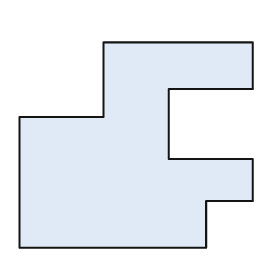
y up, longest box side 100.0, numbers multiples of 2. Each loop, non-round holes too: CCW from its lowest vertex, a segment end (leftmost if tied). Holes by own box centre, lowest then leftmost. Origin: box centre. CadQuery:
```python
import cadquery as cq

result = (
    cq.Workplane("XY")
    .moveTo(-50.0, -44.0)
    .lineTo(30.0, -44.0)
    .lineTo(30.0, -24.0)
    .lineTo(50.0, -24.0)
    .lineTo(50.0, -6.0)
    .lineTo(14.0, -6.0)
    .lineTo(14.0, 24.0)
    .lineTo(50.0, 24.0)
    .lineTo(50.0, 44.0)
    .lineTo(-14.0, 44.0)
    .lineTo(-14.0, 12.0)
    .lineTo(-50.0, 12.0)
    .close()
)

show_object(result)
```